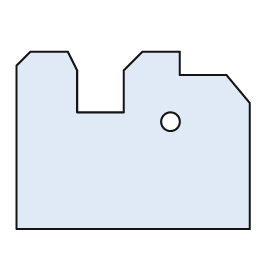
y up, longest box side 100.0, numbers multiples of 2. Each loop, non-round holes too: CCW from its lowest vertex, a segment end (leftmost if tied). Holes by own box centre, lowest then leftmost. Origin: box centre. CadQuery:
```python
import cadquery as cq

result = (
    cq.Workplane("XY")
    .moveTo(-50.0, -38.0)
    .lineTo(50.0, -38.0)
    .lineTo(50.0, 16.0)
    .lineTo(40.0, 28.0)
    .lineTo(20.0, 28.0)
    .lineTo(20.0, 38.0)
    .lineTo(4.0, 38.0)
    .lineTo(-4.0, 30.0)
    .lineTo(-4.0, 12.0)
    .lineTo(-24.0, 12.0)
    .lineTo(-24.0, 30.0)
    .lineTo(-28.0, 38.0)
    .lineTo(-44.0, 38.0)
    .lineTo(-50.0, 32.0)
    .close()
    .moveTo(16.0, 8.0)
    .circle(4.0)
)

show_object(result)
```